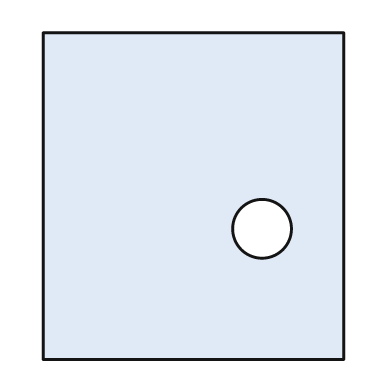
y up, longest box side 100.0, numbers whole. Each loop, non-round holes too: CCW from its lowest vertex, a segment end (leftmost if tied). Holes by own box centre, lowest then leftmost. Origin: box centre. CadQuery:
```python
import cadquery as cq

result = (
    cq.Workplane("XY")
    .moveTo(-46.0, -50.0)
    .lineTo(46.0, -50.0)
    .lineTo(46.0, 50.0)
    .lineTo(-46.0, 50.0)
    .close()
    .moveTo(21.0, -10.0)
    .circle(9.0)
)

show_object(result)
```